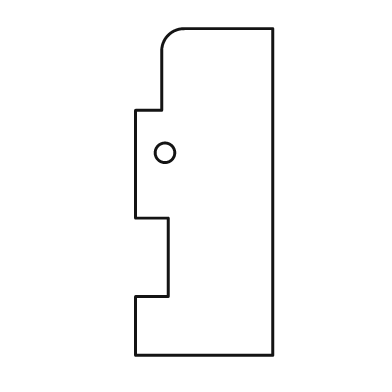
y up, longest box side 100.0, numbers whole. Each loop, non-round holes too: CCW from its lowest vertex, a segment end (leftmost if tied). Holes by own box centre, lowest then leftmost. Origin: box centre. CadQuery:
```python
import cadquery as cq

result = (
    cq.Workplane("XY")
    .moveTo(-21.0, -50.0)
    .lineTo(21.0, -50.0)
    .lineTo(21.0, 50.0)
    .lineTo(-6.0, 50.0)
    .threePointArc((-11.0, 48.0), (-13.0, 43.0))
    .lineTo(-13.0, 25.0)
    .lineTo(-21.0, 25.0)
    .lineTo(-21.0, -8.0)
    .lineTo(-11.0, -8.0)
    .lineTo(-11.0, -32.0)
    .lineTo(-21.0, -32.0)
    .close()
    .moveTo(-12.0, 12.0)
    .circle(3.0)
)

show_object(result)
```